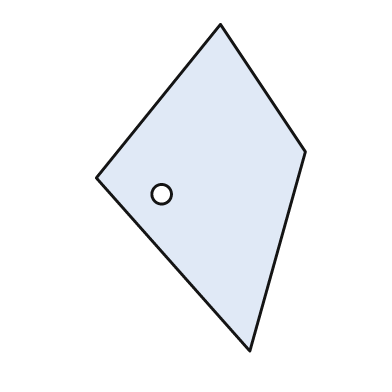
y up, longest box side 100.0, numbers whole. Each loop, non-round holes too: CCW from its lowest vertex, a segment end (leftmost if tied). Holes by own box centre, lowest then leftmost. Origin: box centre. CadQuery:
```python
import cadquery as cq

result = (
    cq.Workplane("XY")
    .moveTo(15.0, -50.0)
    .lineTo(32.0, 11.0)
    .lineTo(6.0, 50.0)
    .lineTo(-32.0, 3.0)
    .close()
    .moveTo(-12.0, -2.0)
    .circle(3.0)
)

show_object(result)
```